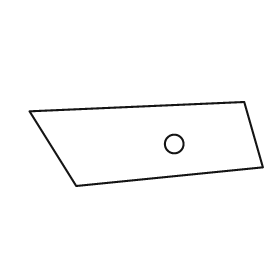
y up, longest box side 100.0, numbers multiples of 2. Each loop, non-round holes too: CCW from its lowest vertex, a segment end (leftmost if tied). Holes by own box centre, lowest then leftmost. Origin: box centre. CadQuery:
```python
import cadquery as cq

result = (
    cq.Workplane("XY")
    .moveTo(-30.0, -18.0)
    .lineTo(50.0, -10.0)
    .lineTo(42.0, 18.0)
    .lineTo(-50.0, 14.0)
    .close()
    .moveTo(12.0, 0.0)
    .circle(4.0)
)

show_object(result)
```